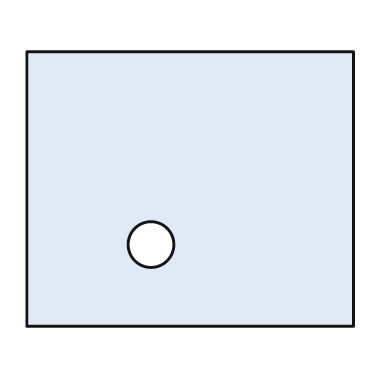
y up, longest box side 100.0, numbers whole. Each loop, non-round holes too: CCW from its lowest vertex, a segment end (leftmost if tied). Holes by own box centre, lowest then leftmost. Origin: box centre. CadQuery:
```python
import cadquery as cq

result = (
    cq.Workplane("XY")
    .moveTo(-50.0, -42.0)
    .lineTo(50.0, -42.0)
    .lineTo(50.0, 42.0)
    .lineTo(-50.0, 42.0)
    .close()
    .moveTo(-12.0, -17.0)
    .circle(7.0)
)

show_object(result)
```